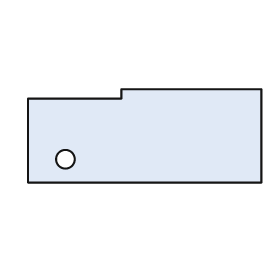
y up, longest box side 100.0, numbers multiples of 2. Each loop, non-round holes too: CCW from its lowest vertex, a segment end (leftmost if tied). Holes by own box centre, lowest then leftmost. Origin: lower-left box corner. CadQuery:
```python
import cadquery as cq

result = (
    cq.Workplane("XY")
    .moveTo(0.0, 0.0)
    .lineTo(100.0, 0.0)
    .lineTo(100.0, 40.0)
    .lineTo(40.0, 40.0)
    .lineTo(40.0, 36.0)
    .lineTo(0.0, 36.0)
    .close()
    .moveTo(16.0, 10.0)
    .circle(4.0)
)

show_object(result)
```